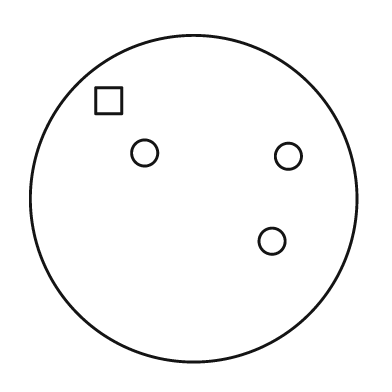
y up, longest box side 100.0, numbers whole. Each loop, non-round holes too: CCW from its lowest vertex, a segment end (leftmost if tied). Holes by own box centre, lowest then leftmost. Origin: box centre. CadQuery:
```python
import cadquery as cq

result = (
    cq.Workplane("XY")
    .moveTo(0.0, 0.0)
    .circle(50.0)
    .moveTo(24.0, -13.0)
    .circle(4.0)
    .moveTo(29.0, 13.0)
    .circle(4.0)
    .moveTo(-15.0, 14.0)
    .circle(4.0)
    .moveTo(-30.0, 26.0)
    .lineTo(-22.0, 26.0)
    .lineTo(-22.0, 34.0)
    .lineTo(-30.0, 34.0)
    .close()
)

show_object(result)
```